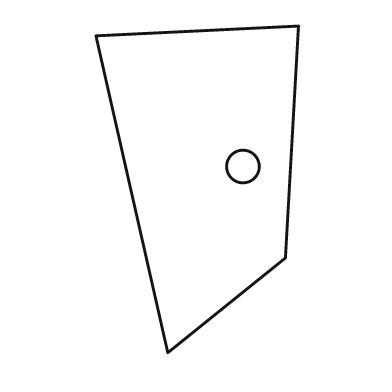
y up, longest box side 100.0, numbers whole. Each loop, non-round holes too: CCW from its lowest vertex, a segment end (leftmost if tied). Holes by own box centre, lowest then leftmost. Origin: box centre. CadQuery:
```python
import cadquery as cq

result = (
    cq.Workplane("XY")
    .moveTo(-9.0, -50.0)
    .lineTo(27.0, -21.0)
    .lineTo(31.0, 50.0)
    .lineTo(-31.0, 47.0)
    .close()
    .moveTo(14.0, 7.0)
    .circle(5.0)
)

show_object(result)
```